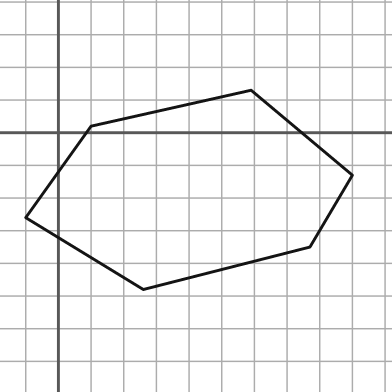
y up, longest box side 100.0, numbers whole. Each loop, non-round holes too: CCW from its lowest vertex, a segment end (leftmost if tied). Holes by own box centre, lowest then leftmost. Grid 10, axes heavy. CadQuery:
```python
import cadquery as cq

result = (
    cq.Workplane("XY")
    .moveTo(26.0, -48.0)
    .lineTo(77.0, -35.0)
    .lineTo(90.0, -13.0)
    .lineTo(59.0, 13.0)
    .lineTo(10.0, 2.0)
    .lineTo(-10.0, -26.0)
    .close()
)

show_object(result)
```